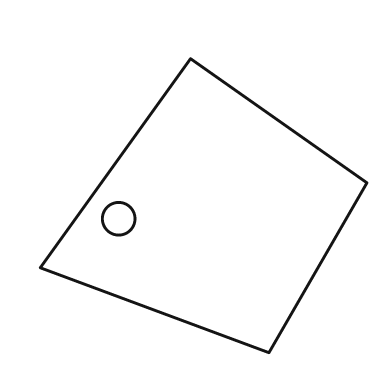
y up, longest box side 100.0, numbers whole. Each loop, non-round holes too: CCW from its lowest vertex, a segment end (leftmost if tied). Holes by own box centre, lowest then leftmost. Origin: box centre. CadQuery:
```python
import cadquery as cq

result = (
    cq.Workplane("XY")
    .moveTo(20.0, -45.0)
    .lineTo(50.0, 7.0)
    .lineTo(-4.0, 45.0)
    .lineTo(-50.0, -19.0)
    .close()
    .moveTo(-26.0, -4.0)
    .circle(5.0)
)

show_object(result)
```